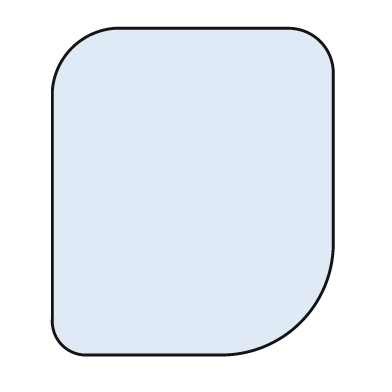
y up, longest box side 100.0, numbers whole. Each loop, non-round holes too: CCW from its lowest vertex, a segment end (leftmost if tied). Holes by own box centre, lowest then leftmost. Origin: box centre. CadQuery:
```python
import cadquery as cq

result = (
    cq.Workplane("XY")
    .moveTo(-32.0, -50.0)
    .lineTo(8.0, -50.0)
    .threePointArc((33.0, -40.0), (43.0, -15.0))
    .lineTo(43.0, 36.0)
    .threePointArc((39.0, 46.0), (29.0, 50.0))
    .lineTo(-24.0, 50.0)
    .threePointArc((-37.0, 44.0), (-43.0, 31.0))
    .lineTo(-43.0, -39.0)
    .threePointArc((-40.0, -47.0), (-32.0, -50.0))
    .close()
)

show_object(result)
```